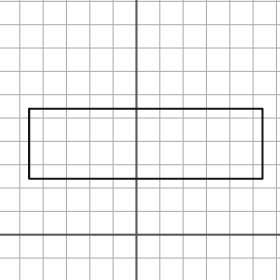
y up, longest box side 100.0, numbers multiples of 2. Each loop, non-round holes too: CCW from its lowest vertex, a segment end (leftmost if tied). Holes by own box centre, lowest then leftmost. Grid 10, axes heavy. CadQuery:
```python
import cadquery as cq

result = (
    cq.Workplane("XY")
    .moveTo(-46.0, 24.0)
    .lineTo(54.0, 24.0)
    .lineTo(54.0, 54.0)
    .lineTo(-46.0, 54.0)
    .close()
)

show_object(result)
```